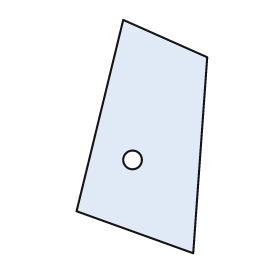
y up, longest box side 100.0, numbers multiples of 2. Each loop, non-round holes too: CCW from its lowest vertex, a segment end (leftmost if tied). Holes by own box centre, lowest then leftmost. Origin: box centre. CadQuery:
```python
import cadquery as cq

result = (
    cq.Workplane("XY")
    .moveTo(22.0, -50.0)
    .lineTo(28.0, 34.0)
    .lineTo(-8.0, 50.0)
    .lineTo(-28.0, -32.0)
    .close()
    .moveTo(-4.0, -10.0)
    .circle(4.0)
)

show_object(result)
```